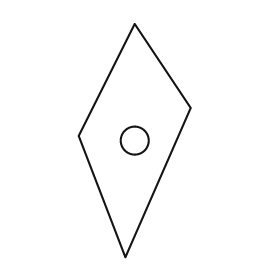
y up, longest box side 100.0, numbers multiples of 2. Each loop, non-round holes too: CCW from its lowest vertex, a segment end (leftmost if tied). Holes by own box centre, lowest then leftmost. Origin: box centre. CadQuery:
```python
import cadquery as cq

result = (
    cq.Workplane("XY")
    .moveTo(-4.0, -50.0)
    .lineTo(24.0, 14.0)
    .lineTo(0.0, 50.0)
    .lineTo(-24.0, 2.0)
    .close()
    .moveTo(0.0, 0.0)
    .circle(6.0)
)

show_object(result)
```